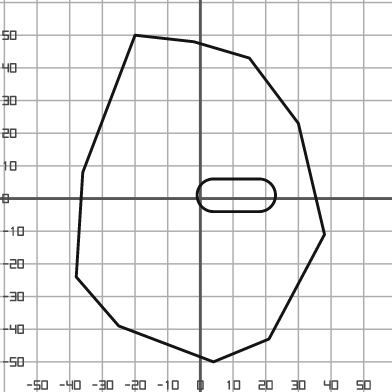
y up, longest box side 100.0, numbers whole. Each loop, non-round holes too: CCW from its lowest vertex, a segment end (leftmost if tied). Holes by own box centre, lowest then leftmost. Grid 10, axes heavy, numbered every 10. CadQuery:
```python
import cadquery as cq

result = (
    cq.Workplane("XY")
    .moveTo(4.0, -50.0)
    .lineTo(21.0, -43.0)
    .lineTo(38.0, -11.0)
    .lineTo(30.0, 23.0)
    .lineTo(15.0, 43.0)
    .lineTo(-2.0, 48.0)
    .lineTo(-20.0, 50.0)
    .lineTo(-36.0, 8.0)
    .lineTo(-38.0, -24.0)
    .lineTo(-25.0, -39.0)
    .close()
    .moveTo(4.0, -4.0)
    .lineTo(18.0, -4.0)
    .threePointArc((23.0, 1.0), (18.0, 6.0))
    .lineTo(4.0, 6.0)
    .threePointArc((-1.0, 1.0), (4.0, -4.0))
    .close()
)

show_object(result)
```